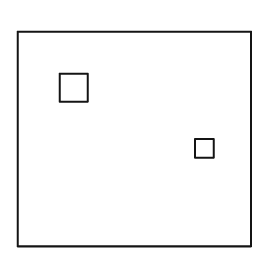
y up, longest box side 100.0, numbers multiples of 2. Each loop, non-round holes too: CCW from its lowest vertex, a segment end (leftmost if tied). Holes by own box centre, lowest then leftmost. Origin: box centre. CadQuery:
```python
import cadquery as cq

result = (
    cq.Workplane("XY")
    .moveTo(-50.0, -46.0)
    .lineTo(50.0, -46.0)
    .lineTo(50.0, 46.0)
    .lineTo(-50.0, 46.0)
    .close()
    .moveTo(26.0, -8.0)
    .lineTo(34.0, -8.0)
    .lineTo(34.0, 0.0)
    .lineTo(26.0, 0.0)
    .close()
    .moveTo(-32.0, 16.0)
    .lineTo(-20.0, 16.0)
    .lineTo(-20.0, 28.0)
    .lineTo(-32.0, 28.0)
    .close()
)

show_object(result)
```